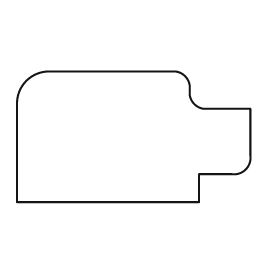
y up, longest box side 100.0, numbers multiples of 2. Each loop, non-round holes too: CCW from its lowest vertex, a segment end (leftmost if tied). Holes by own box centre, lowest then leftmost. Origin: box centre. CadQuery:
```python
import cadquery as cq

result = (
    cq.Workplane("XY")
    .moveTo(-50.0, -28.0)
    .lineTo(28.0, -28.0)
    .lineTo(28.0, -16.0)
    .lineTo(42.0, -16.0)
    .threePointArc((48.0, -14.0), (50.0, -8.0))
    .lineTo(50.0, 12.0)
    .lineTo(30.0, 12.0)
    .threePointArc((26.0, 14.0), (24.0, 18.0))
    .lineTo(24.0, 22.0)
    .threePointArc((22.0, 26.0), (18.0, 28.0))
    .lineTo(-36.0, 28.0)
    .threePointArc((-46.0, 24.0), (-50.0, 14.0))
    .close()
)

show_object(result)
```